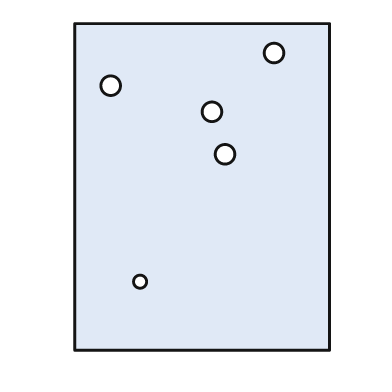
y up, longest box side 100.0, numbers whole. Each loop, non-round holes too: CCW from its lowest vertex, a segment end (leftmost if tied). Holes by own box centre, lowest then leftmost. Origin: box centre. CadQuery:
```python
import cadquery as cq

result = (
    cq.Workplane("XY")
    .moveTo(-39.0, -50.0)
    .lineTo(39.0, -50.0)
    .lineTo(39.0, 50.0)
    .lineTo(-39.0, 50.0)
    .close()
    .moveTo(-19.0, -29.0)
    .circle(2.0)
    .moveTo(7.0, 10.0)
    .circle(3.0)
    .moveTo(3.0, 23.0)
    .circle(3.0)
    .moveTo(-28.0, 31.0)
    .circle(3.0)
    .moveTo(22.0, 41.0)
    .circle(3.0)
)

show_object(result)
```